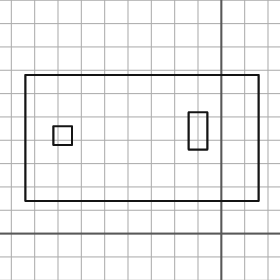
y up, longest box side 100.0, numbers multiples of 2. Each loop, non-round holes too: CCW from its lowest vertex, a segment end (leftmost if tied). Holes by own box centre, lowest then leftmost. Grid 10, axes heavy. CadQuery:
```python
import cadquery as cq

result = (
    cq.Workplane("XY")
    .moveTo(-84.0, 14.0)
    .lineTo(16.0, 14.0)
    .lineTo(16.0, 68.0)
    .lineTo(-84.0, 68.0)
    .close()
    .moveTo(-72.0, 38.0)
    .lineTo(-64.0, 38.0)
    .lineTo(-64.0, 46.0)
    .lineTo(-72.0, 46.0)
    .close()
    .moveTo(-14.0, 36.0)
    .lineTo(-6.0, 36.0)
    .lineTo(-6.0, 52.0)
    .lineTo(-14.0, 52.0)
    .close()
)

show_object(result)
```